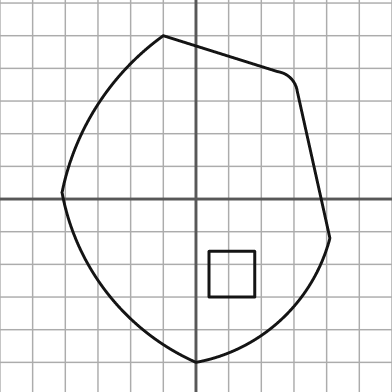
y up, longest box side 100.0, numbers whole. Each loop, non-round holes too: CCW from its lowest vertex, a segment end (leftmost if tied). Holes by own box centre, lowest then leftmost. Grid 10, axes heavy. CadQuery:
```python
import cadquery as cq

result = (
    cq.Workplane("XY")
    .moveTo(0.0, -50.0)
    .threePointArc((26.0, -37.0), (41.0, -12.0))
    .lineTo(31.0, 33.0)
    .threePointArc((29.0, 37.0), (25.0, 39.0))
    .lineTo(-10.0, 50.0)
    .threePointArc((-30.0, 29.0), (-41.0, 2.0))
    .threePointArc((-27.0, -29.0), (0.0, -50.0))
    .close()
    .moveTo(4.0, -30.0)
    .lineTo(18.0, -30.0)
    .lineTo(18.0, -16.0)
    .lineTo(4.0, -16.0)
    .close()
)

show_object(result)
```